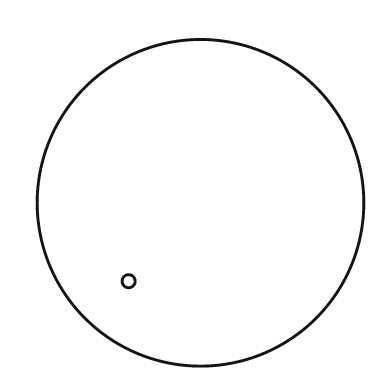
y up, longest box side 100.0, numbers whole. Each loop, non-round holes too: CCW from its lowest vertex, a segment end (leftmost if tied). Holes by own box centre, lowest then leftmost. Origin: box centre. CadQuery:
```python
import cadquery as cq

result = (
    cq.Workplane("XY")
    .moveTo(0.0, 0.0)
    .circle(50.0)
    .moveTo(-22.0, -24.0)
    .circle(2.0)
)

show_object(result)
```